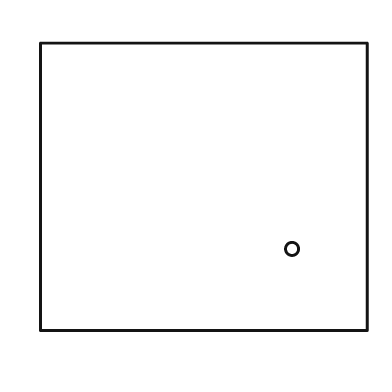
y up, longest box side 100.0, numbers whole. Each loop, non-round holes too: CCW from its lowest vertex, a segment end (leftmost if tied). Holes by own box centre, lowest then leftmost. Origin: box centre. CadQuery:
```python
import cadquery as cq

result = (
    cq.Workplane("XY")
    .moveTo(-50.0, -44.0)
    .lineTo(50.0, -44.0)
    .lineTo(50.0, 44.0)
    .lineTo(-50.0, 44.0)
    .close()
    .moveTo(27.0, -19.0)
    .circle(2.0)
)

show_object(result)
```